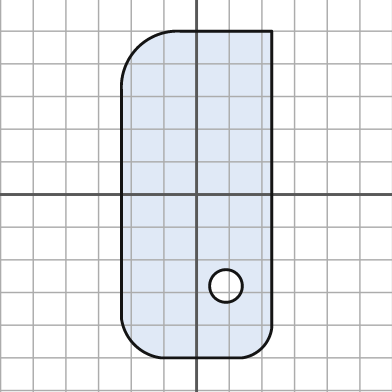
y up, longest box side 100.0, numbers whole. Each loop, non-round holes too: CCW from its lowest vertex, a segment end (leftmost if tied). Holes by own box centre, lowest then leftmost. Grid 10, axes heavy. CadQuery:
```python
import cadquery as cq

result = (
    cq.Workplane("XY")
    .moveTo(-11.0, -50.0)
    .lineTo(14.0, -50.0)
    .threePointArc((20.0, -47.0), (23.0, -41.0))
    .lineTo(23.0, 50.0)
    .lineTo(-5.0, 50.0)
    .threePointArc((-18.0, 45.0), (-23.0, 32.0))
    .lineTo(-23.0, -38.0)
    .threePointArc((-19.0, -46.0), (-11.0, -50.0))
    .close()
    .moveTo(9.0, -28.0)
    .circle(5.0)
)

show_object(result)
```